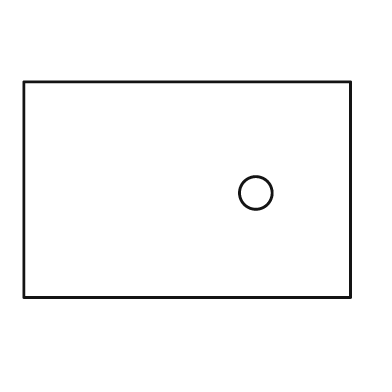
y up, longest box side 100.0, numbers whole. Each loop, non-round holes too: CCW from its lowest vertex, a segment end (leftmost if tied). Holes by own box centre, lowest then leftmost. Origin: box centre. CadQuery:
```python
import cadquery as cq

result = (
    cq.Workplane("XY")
    .moveTo(-50.0, -33.0)
    .lineTo(50.0, -33.0)
    .lineTo(50.0, 33.0)
    .lineTo(-50.0, 33.0)
    .close()
    .moveTo(21.0, -1.0)
    .circle(5.0)
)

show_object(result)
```